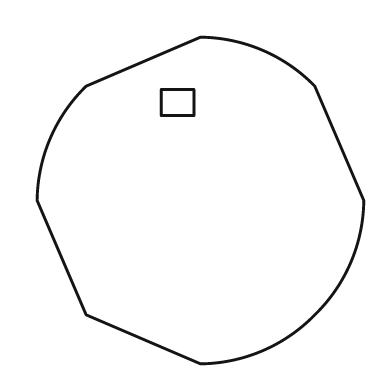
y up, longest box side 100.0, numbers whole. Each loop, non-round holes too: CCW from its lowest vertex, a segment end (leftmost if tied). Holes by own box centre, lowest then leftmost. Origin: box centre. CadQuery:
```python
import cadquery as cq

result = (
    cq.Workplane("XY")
    .moveTo(0.0, -50.0)
    .threePointArc((19.0, -46.0), (35.0, -35.0))
    .threePointArc((46.0, -19.0), (50.0, 0.0))
    .lineTo(35.0, 35.0)
    .threePointArc((19.0, 46.0), (0.0, 50.0))
    .lineTo(-35.0, 35.0)
    .threePointArc((-46.0, 19.0), (-50.0, 0.0))
    .lineTo(-35.0, -35.0)
    .close()
    .moveTo(-12.0, 26.0)
    .lineTo(-2.0, 26.0)
    .lineTo(-2.0, 34.0)
    .lineTo(-12.0, 34.0)
    .close()
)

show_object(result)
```